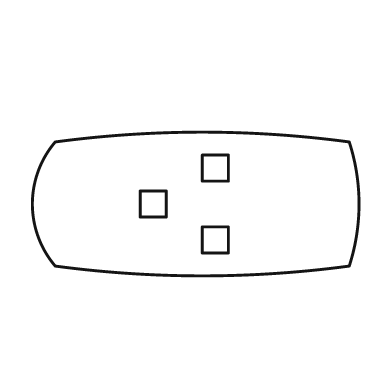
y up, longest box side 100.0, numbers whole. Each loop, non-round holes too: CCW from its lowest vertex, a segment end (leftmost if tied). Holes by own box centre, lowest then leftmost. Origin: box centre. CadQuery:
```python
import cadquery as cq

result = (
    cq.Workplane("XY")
    .moveTo(-43.0, -19.0)
    .threePointArc((2.0, -22.0), (47.0, -19.0))
    .threePointArc((50.0, 0.0), (47.0, 19.0))
    .threePointArc((2.0, 22.0), (-43.0, 19.0))
    .threePointArc((-50.0, 0.0), (-43.0, -19.0))
    .close()
    .moveTo(2.0, -15.0)
    .lineTo(10.0, -15.0)
    .lineTo(10.0, -7.0)
    .lineTo(2.0, -7.0)
    .close()
    .moveTo(-17.0, -4.0)
    .lineTo(-9.0, -4.0)
    .lineTo(-9.0, 4.0)
    .lineTo(-17.0, 4.0)
    .close()
    .moveTo(2.0, 7.0)
    .lineTo(10.0, 7.0)
    .lineTo(10.0, 15.0)
    .lineTo(2.0, 15.0)
    .close()
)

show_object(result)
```